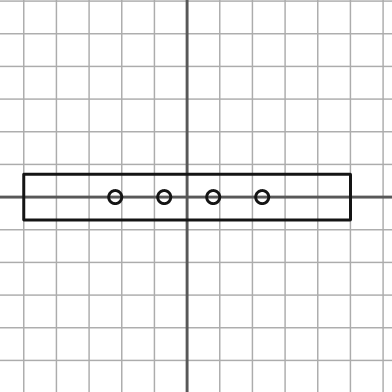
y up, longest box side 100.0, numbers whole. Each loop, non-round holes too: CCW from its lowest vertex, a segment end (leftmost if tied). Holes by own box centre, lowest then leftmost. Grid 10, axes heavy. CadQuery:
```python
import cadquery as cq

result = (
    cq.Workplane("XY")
    .moveTo(-50.0, -7.0)
    .lineTo(50.0, -7.0)
    .lineTo(50.0, 7.0)
    .lineTo(-50.0, 7.0)
    .close()
    .moveTo(-22.0, 0.0)
    .circle(2.0)
    .moveTo(-7.0, 0.0)
    .circle(2.0)
    .moveTo(8.0, 0.0)
    .circle(2.0)
    .moveTo(23.0, 0.0)
    .circle(2.0)
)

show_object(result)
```